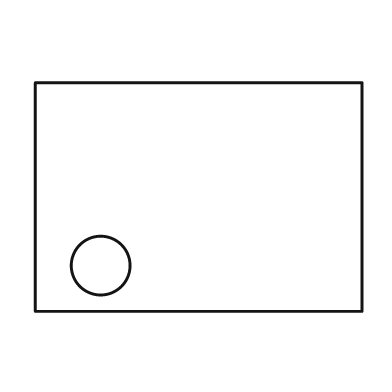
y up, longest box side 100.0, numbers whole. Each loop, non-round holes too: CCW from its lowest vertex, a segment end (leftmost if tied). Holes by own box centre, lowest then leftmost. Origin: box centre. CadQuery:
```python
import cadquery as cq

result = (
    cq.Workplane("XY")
    .moveTo(-50.0, -35.0)
    .lineTo(50.0, -35.0)
    .lineTo(50.0, 35.0)
    .lineTo(-50.0, 35.0)
    .close()
    .moveTo(-30.0, -21.0)
    .circle(9.0)
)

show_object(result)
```